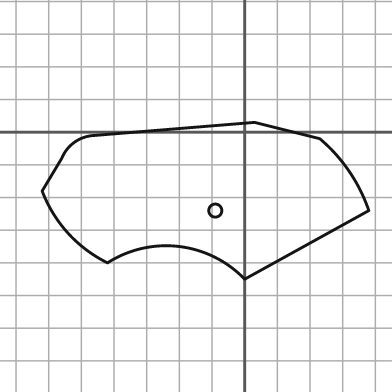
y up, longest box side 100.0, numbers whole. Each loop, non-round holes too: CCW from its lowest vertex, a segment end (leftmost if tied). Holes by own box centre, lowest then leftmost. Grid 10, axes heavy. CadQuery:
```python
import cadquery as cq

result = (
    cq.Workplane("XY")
    .moveTo(0.0, -45.0)
    .lineTo(38.0, -24.0)
    .threePointArc((32.0, -12.0), (23.0, -2.0))
    .lineTo(3.0, 3.0)
    .lineTo(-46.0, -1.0)
    .threePointArc((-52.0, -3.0), (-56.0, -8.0))
    .lineTo(-62.0, -18.0)
    .threePointArc((-54.0, -31.0), (-42.0, -40.0))
    .threePointArc((-20.0, -35.0), (0.0, -45.0))
    .close()
    .moveTo(-9.0, -24.0)
    .circle(2.0)
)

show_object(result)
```